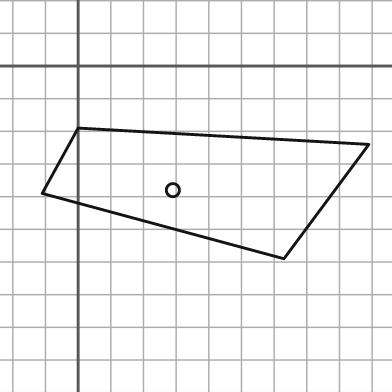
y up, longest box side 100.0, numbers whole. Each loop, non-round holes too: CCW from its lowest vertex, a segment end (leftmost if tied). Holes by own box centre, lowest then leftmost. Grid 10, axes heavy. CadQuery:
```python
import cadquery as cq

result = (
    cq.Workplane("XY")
    .moveTo(63.0, -59.0)
    .lineTo(89.0, -24.0)
    .lineTo(0.0, -19.0)
    .lineTo(-11.0, -39.0)
    .close()
    .moveTo(29.0, -38.0)
    .circle(2.0)
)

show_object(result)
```